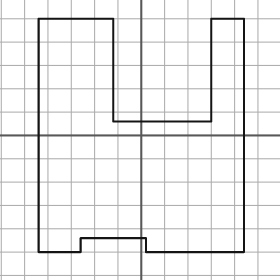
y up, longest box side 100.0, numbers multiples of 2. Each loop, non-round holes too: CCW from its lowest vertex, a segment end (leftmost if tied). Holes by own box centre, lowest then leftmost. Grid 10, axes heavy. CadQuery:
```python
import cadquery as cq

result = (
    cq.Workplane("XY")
    .moveTo(-44.0, -50.0)
    .lineTo(-26.0, -50.0)
    .lineTo(-26.0, -44.0)
    .lineTo(2.0, -44.0)
    .lineTo(2.0, -50.0)
    .lineTo(44.0, -50.0)
    .lineTo(44.0, 50.0)
    .lineTo(30.0, 50.0)
    .lineTo(30.0, 6.0)
    .lineTo(-12.0, 6.0)
    .lineTo(-12.0, 50.0)
    .lineTo(-44.0, 50.0)
    .close()
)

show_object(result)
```